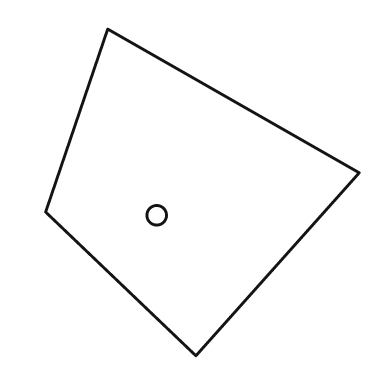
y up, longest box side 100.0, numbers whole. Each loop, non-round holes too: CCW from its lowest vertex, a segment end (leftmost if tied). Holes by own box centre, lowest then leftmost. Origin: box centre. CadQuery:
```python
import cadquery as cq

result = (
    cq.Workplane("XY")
    .moveTo(-2.0, -50.0)
    .lineTo(48.0, 6.0)
    .lineTo(-29.0, 50.0)
    .lineTo(-48.0, -6.0)
    .close()
    .moveTo(-14.0, -7.0)
    .circle(3.0)
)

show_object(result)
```